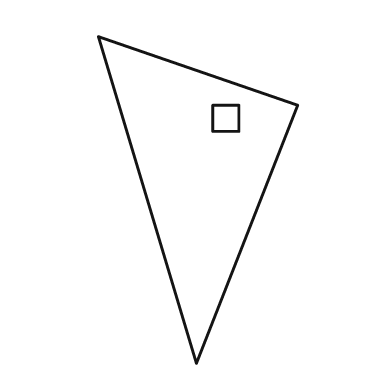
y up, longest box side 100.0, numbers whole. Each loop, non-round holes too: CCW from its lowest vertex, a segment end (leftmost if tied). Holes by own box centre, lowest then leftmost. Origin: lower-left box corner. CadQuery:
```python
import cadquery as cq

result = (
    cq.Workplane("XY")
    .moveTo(30.0, 0.0)
    .lineTo(61.0, 79.0)
    .lineTo(0.0, 100.0)
    .close()
    .moveTo(35.0, 71.0)
    .lineTo(43.0, 71.0)
    .lineTo(43.0, 79.0)
    .lineTo(35.0, 79.0)
    .close()
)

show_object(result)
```